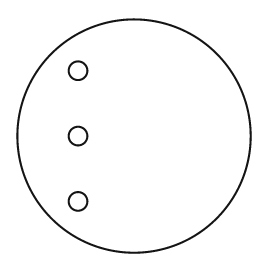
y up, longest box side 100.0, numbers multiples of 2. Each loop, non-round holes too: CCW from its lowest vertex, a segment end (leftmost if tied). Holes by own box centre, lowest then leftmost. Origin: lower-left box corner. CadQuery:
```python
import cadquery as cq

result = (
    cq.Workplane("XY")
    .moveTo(50.0, 50.0)
    .circle(50.0)
    .moveTo(26.0, 22.0)
    .circle(4.0)
    .moveTo(26.0, 50.0)
    .circle(4.0)
    .moveTo(26.0, 78.0)
    .circle(4.0)
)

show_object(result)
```